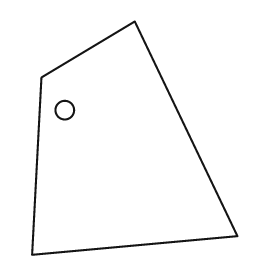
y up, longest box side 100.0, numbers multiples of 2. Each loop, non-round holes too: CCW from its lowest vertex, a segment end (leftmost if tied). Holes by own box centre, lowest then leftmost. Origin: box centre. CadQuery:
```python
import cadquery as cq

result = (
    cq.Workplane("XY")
    .moveTo(-44.0, -50.0)
    .lineTo(44.0, -42.0)
    .lineTo(0.0, 50.0)
    .lineTo(-40.0, 26.0)
    .close()
    .moveTo(-30.0, 12.0)
    .circle(4.0)
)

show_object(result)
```